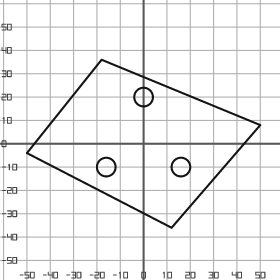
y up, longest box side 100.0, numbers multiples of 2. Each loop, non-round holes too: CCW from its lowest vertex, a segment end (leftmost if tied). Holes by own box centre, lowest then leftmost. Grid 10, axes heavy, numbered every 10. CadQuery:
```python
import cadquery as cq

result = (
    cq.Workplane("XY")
    .moveTo(12.0, -36.0)
    .lineTo(50.0, 8.0)
    .lineTo(-18.0, 36.0)
    .lineTo(-50.0, -4.0)
    .close()
    .moveTo(-16.0, -10.0)
    .circle(4.0)
    .moveTo(16.0, -10.0)
    .circle(4.0)
    .moveTo(0.0, 20.0)
    .circle(4.0)
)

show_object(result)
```